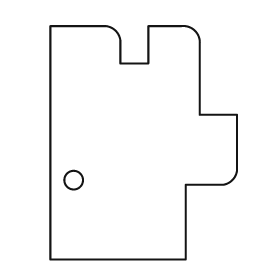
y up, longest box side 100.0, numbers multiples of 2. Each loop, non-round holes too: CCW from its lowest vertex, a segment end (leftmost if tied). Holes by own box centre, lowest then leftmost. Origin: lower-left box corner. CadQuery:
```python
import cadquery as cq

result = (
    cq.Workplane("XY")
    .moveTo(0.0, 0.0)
    .lineTo(58.0, 0.0)
    .lineTo(58.0, 32.0)
    .lineTo(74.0, 32.0)
    .threePointArc((78.0, 34.0), (80.0, 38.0))
    .lineTo(80.0, 62.0)
    .lineTo(64.0, 62.0)
    .lineTo(64.0, 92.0)
    .threePointArc((62.0, 98.0), (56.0, 100.0))
    .lineTo(42.0, 100.0)
    .lineTo(42.0, 84.0)
    .lineTo(30.0, 84.0)
    .lineTo(30.0, 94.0)
    .threePointArc((28.0, 98.0), (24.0, 100.0))
    .lineTo(0.0, 100.0)
    .close()
    .moveTo(10.0, 34.0)
    .circle(4.0)
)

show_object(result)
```